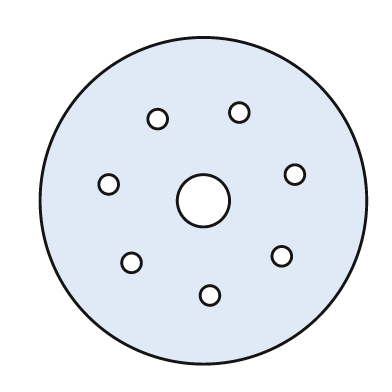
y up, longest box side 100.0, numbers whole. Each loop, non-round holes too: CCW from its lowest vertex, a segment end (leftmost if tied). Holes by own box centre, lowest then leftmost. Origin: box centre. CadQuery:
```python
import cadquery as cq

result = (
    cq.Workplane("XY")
    .moveTo(0.0, 0.0)
    .circle(50.0)
    .moveTo(2.0, -29.0)
    .circle(3.0)
    .moveTo(-22.0, -19.0)
    .circle(3.0)
    .moveTo(24.0, -17.0)
    .circle(3.0)
    .moveTo(0.0, 0.0)
    .circle(8.0)
    .moveTo(-29.0, 5.0)
    .circle(3.0)
    .moveTo(28.0, 8.0)
    .circle(3.0)
    .moveTo(-14.0, 25.0)
    .circle(3.0)
    .moveTo(11.0, 27.0)
    .circle(3.0)
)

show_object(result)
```